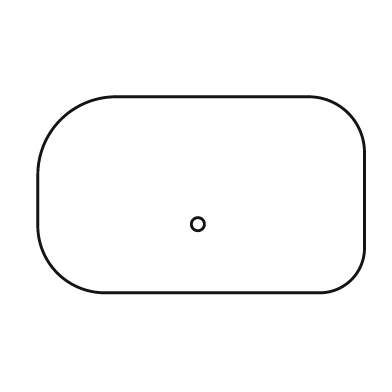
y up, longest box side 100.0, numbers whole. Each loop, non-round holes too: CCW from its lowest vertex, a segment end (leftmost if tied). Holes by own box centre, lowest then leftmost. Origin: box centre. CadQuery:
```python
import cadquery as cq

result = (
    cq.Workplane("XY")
    .moveTo(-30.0, -30.0)
    .lineTo(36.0, -30.0)
    .threePointArc((46.0, -26.0), (50.0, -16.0))
    .lineTo(50.0, 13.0)
    .threePointArc((45.0, 25.0), (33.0, 30.0))
    .lineTo(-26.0, 30.0)
    .threePointArc((-43.0, 23.0), (-50.0, 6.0))
    .lineTo(-50.0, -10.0)
    .threePointArc((-44.0, -24.0), (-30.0, -30.0))
    .close()
    .moveTo(-1.0, -9.0)
    .circle(2.0)
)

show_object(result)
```